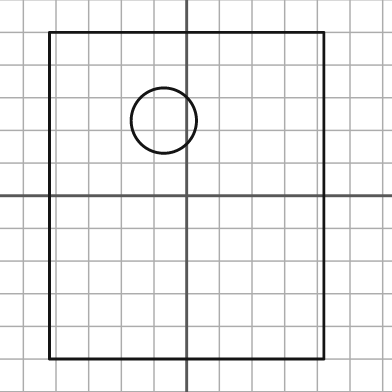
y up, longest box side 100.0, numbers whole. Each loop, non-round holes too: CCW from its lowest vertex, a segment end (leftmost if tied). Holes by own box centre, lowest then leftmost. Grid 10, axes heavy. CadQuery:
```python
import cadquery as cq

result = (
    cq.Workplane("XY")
    .moveTo(-42.0, -50.0)
    .lineTo(42.0, -50.0)
    .lineTo(42.0, 50.0)
    .lineTo(-42.0, 50.0)
    .close()
    .moveTo(-7.0, 23.0)
    .circle(10.0)
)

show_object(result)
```